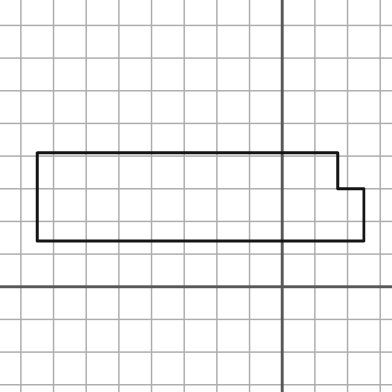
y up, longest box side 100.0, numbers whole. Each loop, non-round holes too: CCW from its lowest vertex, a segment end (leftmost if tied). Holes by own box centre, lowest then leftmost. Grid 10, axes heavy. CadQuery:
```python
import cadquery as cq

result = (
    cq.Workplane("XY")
    .moveTo(-75.0, 14.0)
    .lineTo(25.0, 14.0)
    .lineTo(25.0, 30.0)
    .lineTo(17.0, 30.0)
    .lineTo(17.0, 41.0)
    .lineTo(-75.0, 41.0)
    .close()
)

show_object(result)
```